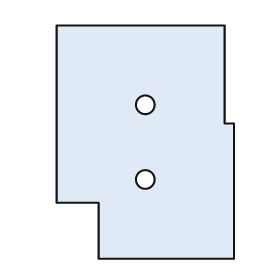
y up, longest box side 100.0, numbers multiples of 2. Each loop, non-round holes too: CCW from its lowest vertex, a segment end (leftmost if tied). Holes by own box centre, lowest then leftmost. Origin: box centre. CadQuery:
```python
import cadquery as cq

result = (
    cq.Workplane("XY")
    .moveTo(-20.0, -50.0)
    .lineTo(38.0, -50.0)
    .lineTo(38.0, 8.0)
    .lineTo(34.0, 8.0)
    .lineTo(34.0, 50.0)
    .lineTo(-38.0, 50.0)
    .lineTo(-38.0, -26.0)
    .lineTo(-20.0, -26.0)
    .close()
    .moveTo(0.0, -16.0)
    .circle(4.0)
    .moveTo(0.0, 16.0)
    .circle(4.0)
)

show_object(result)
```